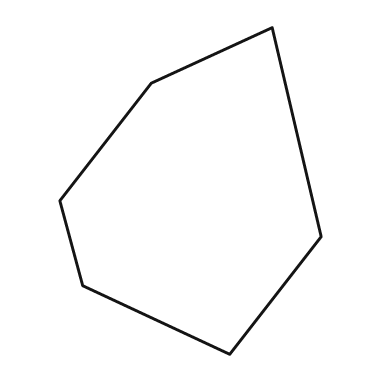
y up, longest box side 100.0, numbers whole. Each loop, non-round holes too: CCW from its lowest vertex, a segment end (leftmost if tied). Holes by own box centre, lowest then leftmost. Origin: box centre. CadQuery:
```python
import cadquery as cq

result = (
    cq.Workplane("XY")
    .moveTo(12.0, -50.0)
    .lineTo(40.0, -14.0)
    .lineTo(25.0, 50.0)
    .lineTo(-12.0, 33.0)
    .lineTo(-40.0, -3.0)
    .lineTo(-33.0, -29.0)
    .close()
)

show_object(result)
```